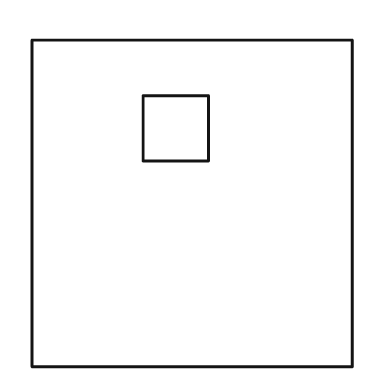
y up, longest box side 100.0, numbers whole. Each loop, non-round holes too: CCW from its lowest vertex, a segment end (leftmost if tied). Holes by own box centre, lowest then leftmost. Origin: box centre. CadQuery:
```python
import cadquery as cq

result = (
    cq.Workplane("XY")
    .moveTo(-49.0, -50.0)
    .lineTo(49.0, -50.0)
    .lineTo(49.0, 50.0)
    .lineTo(-49.0, 50.0)
    .close()
    .moveTo(-15.0, 13.0)
    .lineTo(5.0, 13.0)
    .lineTo(5.0, 33.0)
    .lineTo(-15.0, 33.0)
    .close()
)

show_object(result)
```